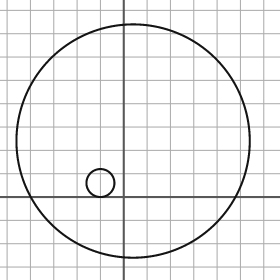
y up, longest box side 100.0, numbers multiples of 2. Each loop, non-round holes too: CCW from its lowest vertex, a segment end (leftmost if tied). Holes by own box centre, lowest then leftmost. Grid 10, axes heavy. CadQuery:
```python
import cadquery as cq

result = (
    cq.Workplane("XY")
    .moveTo(4.0, 24.0)
    .circle(50.0)
    .moveTo(-10.0, 6.0)
    .circle(6.0)
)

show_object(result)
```